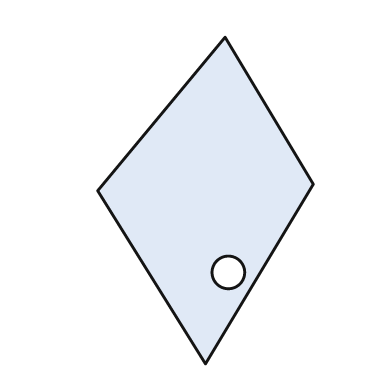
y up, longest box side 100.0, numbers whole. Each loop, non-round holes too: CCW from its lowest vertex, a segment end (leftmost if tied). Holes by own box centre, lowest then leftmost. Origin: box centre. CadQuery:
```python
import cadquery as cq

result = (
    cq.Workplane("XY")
    .moveTo(0.0, -50.0)
    .lineTo(33.0, 5.0)
    .lineTo(6.0, 50.0)
    .lineTo(-33.0, 3.0)
    .close()
    .moveTo(7.0, -22.0)
    .circle(5.0)
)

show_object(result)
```